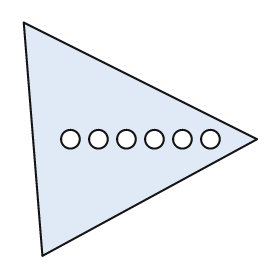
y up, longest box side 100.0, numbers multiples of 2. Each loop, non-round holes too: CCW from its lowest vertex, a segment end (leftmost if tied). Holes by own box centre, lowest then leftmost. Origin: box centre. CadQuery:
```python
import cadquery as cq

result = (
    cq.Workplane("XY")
    .moveTo(-42.0, -50.0)
    .lineTo(50.0, 0.0)
    .lineTo(-50.0, 50.0)
    .close()
    .moveTo(-30.0, 0.0)
    .circle(4.0)
    .moveTo(-18.0, 0.0)
    .circle(4.0)
    .moveTo(-6.0, 0.0)
    .circle(4.0)
    .moveTo(6.0, 0.0)
    .circle(4.0)
    .moveTo(18.0, 0.0)
    .circle(4.0)
    .moveTo(30.0, 0.0)
    .circle(4.0)
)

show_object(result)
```